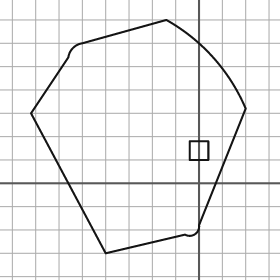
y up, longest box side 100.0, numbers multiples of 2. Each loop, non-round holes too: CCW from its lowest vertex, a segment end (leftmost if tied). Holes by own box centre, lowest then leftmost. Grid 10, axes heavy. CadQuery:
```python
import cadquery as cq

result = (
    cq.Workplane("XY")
    .moveTo(-40.0, -30.0)
    .lineTo(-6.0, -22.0)
    .threePointArc((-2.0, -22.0), (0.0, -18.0))
    .lineTo(20.0, 32.0)
    .threePointArc((6.0, 54.0), (-14.0, 70.0))
    .lineTo(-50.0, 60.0)
    .threePointArc((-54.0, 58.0), (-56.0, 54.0))
    .lineTo(-72.0, 30.0)
    .close()
    .moveTo(-4.0, 10.0)
    .lineTo(4.0, 10.0)
    .lineTo(4.0, 18.0)
    .lineTo(-4.0, 18.0)
    .close()
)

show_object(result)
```